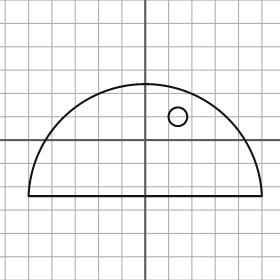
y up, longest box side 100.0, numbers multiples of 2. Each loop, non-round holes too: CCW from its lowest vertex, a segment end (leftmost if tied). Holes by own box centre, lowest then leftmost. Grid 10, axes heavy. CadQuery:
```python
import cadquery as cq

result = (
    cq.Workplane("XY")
    .moveTo(-50.0, -24.0)
    .lineTo(50.0, -24.0)
    .threePointArc((0.0, 24.0), (-50.0, -24.0))
    .close()
    .moveTo(14.0, 10.0)
    .circle(4.0)
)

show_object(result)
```